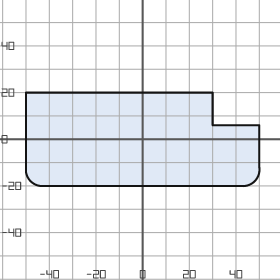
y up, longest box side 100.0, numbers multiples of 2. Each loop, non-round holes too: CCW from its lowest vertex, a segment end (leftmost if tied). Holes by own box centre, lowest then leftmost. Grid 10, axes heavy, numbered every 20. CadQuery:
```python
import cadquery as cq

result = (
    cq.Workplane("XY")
    .moveTo(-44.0, -20.0)
    .lineTo(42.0, -20.0)
    .threePointArc((48.0, -18.0), (50.0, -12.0))
    .lineTo(50.0, 6.0)
    .lineTo(30.0, 6.0)
    .lineTo(30.0, 20.0)
    .lineTo(-50.0, 20.0)
    .lineTo(-50.0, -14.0)
    .threePointArc((-48.0, -18.0), (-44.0, -20.0))
    .close()
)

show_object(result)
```